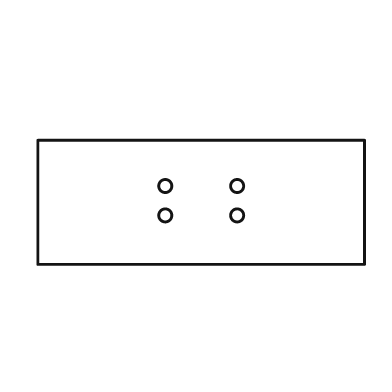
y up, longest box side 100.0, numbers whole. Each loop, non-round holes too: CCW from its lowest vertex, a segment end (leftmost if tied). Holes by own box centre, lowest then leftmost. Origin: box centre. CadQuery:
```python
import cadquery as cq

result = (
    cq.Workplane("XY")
    .moveTo(-50.0, -19.0)
    .lineTo(50.0, -19.0)
    .lineTo(50.0, 19.0)
    .lineTo(-50.0, 19.0)
    .close()
    .moveTo(-11.0, -4.0)
    .circle(2.0)
    .moveTo(11.0, -4.0)
    .circle(2.0)
    .moveTo(-11.0, 5.0)
    .circle(2.0)
    .moveTo(11.0, 5.0)
    .circle(2.0)
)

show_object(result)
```